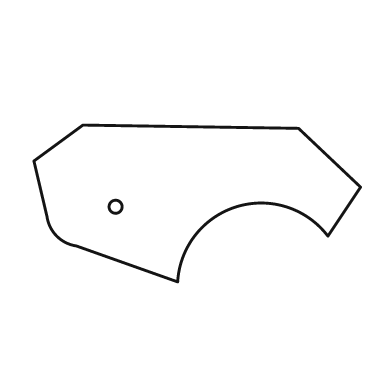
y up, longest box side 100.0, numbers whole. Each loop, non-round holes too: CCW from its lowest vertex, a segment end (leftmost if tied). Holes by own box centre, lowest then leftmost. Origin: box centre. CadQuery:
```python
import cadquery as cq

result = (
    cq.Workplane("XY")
    .moveTo(-6.0, -24.0)
    .threePointArc((12.0, -1.0), (40.0, -10.0))
    .lineTo(50.0, 5.0)
    .lineTo(31.0, 23.0)
    .lineTo(-35.0, 24.0)
    .lineTo(-50.0, 13.0)
    .lineTo(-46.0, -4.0)
    .threePointArc((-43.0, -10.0), (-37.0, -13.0))
    .close()
    .moveTo(-25.0, -1.0)
    .circle(2.0)
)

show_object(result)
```